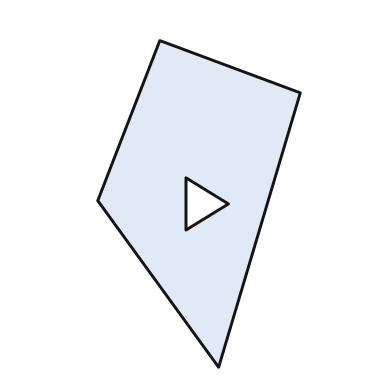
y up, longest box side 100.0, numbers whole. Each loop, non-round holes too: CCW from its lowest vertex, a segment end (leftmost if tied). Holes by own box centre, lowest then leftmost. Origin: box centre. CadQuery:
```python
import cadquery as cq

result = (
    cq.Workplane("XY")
    .moveTo(6.0, -50.0)
    .lineTo(31.0, 34.0)
    .lineTo(-12.0, 50.0)
    .lineTo(-31.0, 1.0)
    .close()
    .moveTo(-4.0, -8.0)
    .lineTo(9.0, 0.0)
    .lineTo(-4.0, 8.0)
    .close()
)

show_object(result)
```